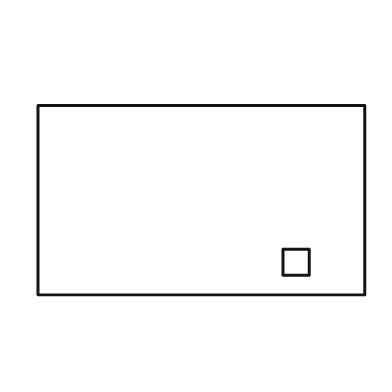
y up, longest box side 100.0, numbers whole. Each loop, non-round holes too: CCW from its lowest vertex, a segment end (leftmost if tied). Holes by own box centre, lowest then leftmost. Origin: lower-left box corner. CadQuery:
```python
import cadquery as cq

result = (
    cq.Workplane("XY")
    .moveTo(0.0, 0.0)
    .lineTo(100.0, 0.0)
    .lineTo(100.0, 58.0)
    .lineTo(0.0, 58.0)
    .close()
    .moveTo(75.0, 6.0)
    .lineTo(83.0, 6.0)
    .lineTo(83.0, 14.0)
    .lineTo(75.0, 14.0)
    .close()
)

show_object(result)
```